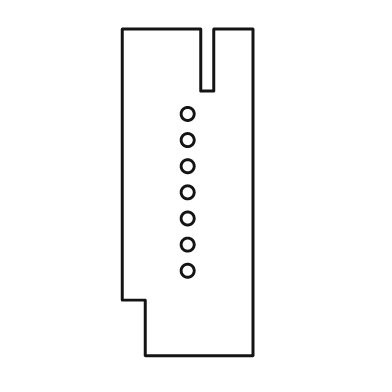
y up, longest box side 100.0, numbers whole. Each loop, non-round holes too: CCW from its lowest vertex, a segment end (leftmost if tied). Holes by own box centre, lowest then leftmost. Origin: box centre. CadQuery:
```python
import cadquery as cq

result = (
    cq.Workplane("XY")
    .moveTo(-13.0, -50.0)
    .lineTo(20.0, -50.0)
    .lineTo(20.0, 50.0)
    .lineTo(8.0, 50.0)
    .lineTo(8.0, 31.0)
    .lineTo(4.0, 31.0)
    .lineTo(4.0, 50.0)
    .lineTo(-20.0, 50.0)
    .lineTo(-20.0, -33.0)
    .lineTo(-13.0, -33.0)
    .close()
    .moveTo(0.0, -24.0)
    .circle(2.0)
    .moveTo(0.0, -16.0)
    .circle(2.0)
    .moveTo(0.0, -8.0)
    .circle(2.0)
    .moveTo(0.0, 0.0)
    .circle(2.0)
    .moveTo(0.0, 8.0)
    .circle(2.0)
    .moveTo(0.0, 16.0)
    .circle(2.0)
    .moveTo(0.0, 24.0)
    .circle(2.0)
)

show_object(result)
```